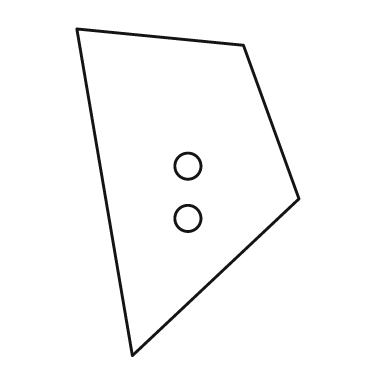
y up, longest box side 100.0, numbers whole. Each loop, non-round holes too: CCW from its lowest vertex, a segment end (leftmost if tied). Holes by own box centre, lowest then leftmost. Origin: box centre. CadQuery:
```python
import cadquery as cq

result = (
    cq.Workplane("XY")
    .moveTo(-17.0, -50.0)
    .lineTo(34.0, -2.0)
    .lineTo(17.0, 45.0)
    .lineTo(-34.0, 50.0)
    .close()
    .moveTo(0.0, -8.0)
    .circle(4.0)
    .moveTo(0.0, 8.0)
    .circle(4.0)
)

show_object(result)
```